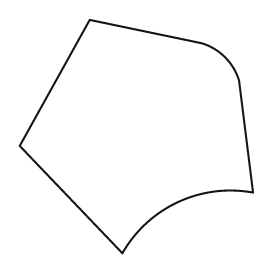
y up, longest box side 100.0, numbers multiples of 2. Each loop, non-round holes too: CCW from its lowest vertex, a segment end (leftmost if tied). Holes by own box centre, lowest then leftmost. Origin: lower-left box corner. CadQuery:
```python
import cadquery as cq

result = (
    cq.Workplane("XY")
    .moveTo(44.0, 0.0)
    .threePointArc((68.0, 22.0), (100.0, 26.0))
    .lineTo(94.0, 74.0)
    .threePointArc((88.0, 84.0), (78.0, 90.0))
    .lineTo(30.0, 100.0)
    .lineTo(0.0, 46.0)
    .close()
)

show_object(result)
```